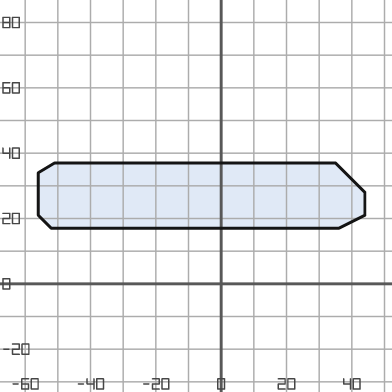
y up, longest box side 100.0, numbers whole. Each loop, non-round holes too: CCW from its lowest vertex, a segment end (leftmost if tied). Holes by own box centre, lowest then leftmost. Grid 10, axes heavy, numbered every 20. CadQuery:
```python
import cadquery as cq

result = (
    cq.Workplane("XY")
    .moveTo(-52.0, 17.0)
    .lineTo(36.0, 17.0)
    .lineTo(44.0, 21.0)
    .lineTo(44.0, 28.0)
    .lineTo(35.0, 37.0)
    .lineTo(-51.0, 37.0)
    .lineTo(-56.0, 34.0)
    .lineTo(-56.0, 21.0)
    .close()
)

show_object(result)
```